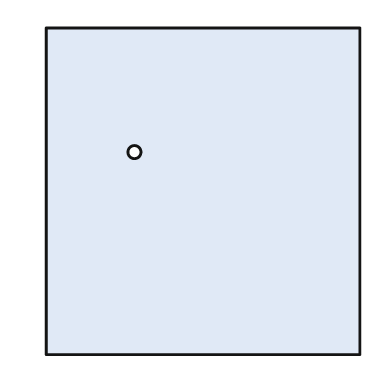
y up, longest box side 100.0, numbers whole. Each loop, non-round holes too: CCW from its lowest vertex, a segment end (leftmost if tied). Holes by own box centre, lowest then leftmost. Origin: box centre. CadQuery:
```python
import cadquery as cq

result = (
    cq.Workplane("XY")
    .moveTo(-48.0, -50.0)
    .lineTo(48.0, -50.0)
    .lineTo(48.0, 50.0)
    .lineTo(-48.0, 50.0)
    .close()
    .moveTo(-21.0, 12.0)
    .circle(2.0)
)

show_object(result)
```